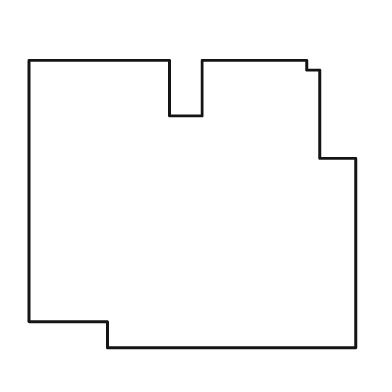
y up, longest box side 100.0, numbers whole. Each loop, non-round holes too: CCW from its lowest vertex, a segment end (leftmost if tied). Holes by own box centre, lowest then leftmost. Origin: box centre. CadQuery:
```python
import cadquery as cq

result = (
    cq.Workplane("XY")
    .moveTo(-26.0, -44.0)
    .lineTo(50.0, -44.0)
    .lineTo(50.0, 14.0)
    .lineTo(39.0, 14.0)
    .lineTo(39.0, 41.0)
    .lineTo(35.0, 41.0)
    .lineTo(35.0, 44.0)
    .lineTo(3.0, 44.0)
    .lineTo(3.0, 27.0)
    .lineTo(-7.0, 27.0)
    .lineTo(-7.0, 44.0)
    .lineTo(-50.0, 44.0)
    .lineTo(-50.0, -36.0)
    .lineTo(-26.0, -36.0)
    .close()
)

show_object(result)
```